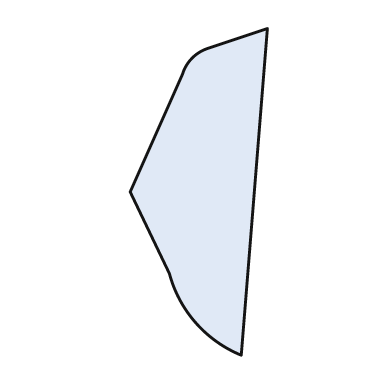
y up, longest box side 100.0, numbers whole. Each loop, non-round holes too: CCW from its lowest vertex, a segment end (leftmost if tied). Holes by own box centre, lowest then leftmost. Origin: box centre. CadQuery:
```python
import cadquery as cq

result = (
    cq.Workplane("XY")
    .moveTo(13.0, -50.0)
    .lineTo(21.0, 50.0)
    .lineTo(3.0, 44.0)
    .threePointArc((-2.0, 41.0), (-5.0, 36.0))
    .lineTo(-21.0, 0.0)
    .lineTo(-9.0, -25.0)
    .threePointArc((-1.0, -40.0), (13.0, -50.0))
    .close()
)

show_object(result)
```